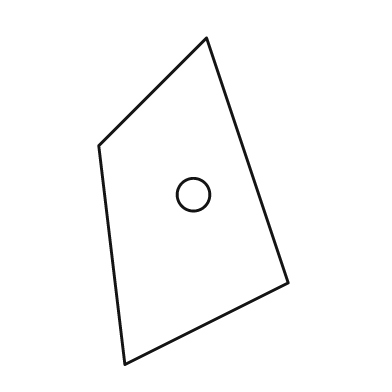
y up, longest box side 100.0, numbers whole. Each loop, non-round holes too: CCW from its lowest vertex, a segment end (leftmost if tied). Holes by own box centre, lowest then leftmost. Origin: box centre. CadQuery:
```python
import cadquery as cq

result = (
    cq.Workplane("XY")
    .moveTo(-21.0, -50.0)
    .lineTo(29.0, -25.0)
    .lineTo(4.0, 50.0)
    .lineTo(-29.0, 17.0)
    .close()
    .moveTo(0.0, 2.0)
    .circle(5.0)
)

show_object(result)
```